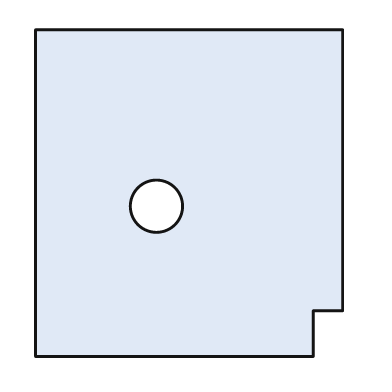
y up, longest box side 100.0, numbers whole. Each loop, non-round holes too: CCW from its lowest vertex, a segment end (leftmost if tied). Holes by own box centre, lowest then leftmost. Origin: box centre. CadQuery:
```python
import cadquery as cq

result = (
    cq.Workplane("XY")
    .moveTo(-47.0, -50.0)
    .lineTo(38.0, -50.0)
    .lineTo(38.0, -36.0)
    .lineTo(47.0, -36.0)
    .lineTo(47.0, 50.0)
    .lineTo(-47.0, 50.0)
    .close()
    .moveTo(-10.0, -4.0)
    .circle(8.0)
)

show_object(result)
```